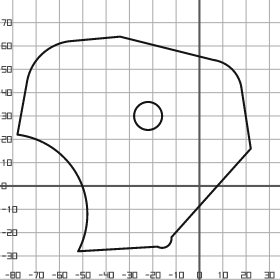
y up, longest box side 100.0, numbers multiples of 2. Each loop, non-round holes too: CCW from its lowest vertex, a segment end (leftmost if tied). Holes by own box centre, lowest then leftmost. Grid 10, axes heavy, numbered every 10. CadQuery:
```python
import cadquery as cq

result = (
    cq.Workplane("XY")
    .moveTo(-52.0, -28.0)
    .lineTo(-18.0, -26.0)
    .threePointArc((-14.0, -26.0), (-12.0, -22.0))
    .lineTo(22.0, 16.0)
    .lineTo(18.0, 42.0)
    .threePointArc((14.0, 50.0), (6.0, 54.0))
    .lineTo(-34.0, 64.0)
    .lineTo(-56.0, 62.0)
    .threePointArc((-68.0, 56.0), (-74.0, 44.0))
    .lineTo(-78.0, 22.0)
    .threePointArc((-52.0, 4.0), (-52.0, -28.0))
    .close()
    .moveTo(-22.0, 30.0)
    .circle(6.0)
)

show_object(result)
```